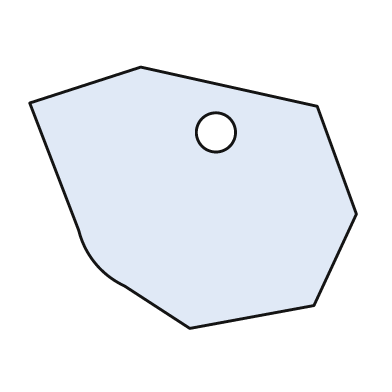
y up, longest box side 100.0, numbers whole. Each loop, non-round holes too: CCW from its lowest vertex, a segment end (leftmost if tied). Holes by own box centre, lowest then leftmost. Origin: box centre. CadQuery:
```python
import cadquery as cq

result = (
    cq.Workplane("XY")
    .moveTo(-1.0, -40.0)
    .lineTo(37.0, -33.0)
    .lineTo(50.0, -5.0)
    .lineTo(38.0, 28.0)
    .lineTo(-16.0, 40.0)
    .lineTo(-50.0, 29.0)
    .lineTo(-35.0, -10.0)
    .threePointArc((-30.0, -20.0), (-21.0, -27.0))
    .close()
    .moveTo(7.0, 20.0)
    .circle(6.0)
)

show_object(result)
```